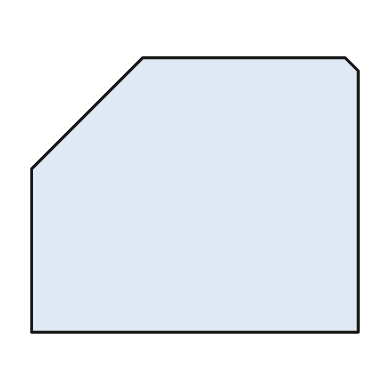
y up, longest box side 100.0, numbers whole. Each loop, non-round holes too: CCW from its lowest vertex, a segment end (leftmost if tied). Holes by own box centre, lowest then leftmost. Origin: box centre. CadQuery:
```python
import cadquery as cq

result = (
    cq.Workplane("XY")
    .moveTo(-50.0, -42.0)
    .lineTo(50.0, -42.0)
    .lineTo(50.0, 38.0)
    .lineTo(46.0, 42.0)
    .lineTo(-16.0, 42.0)
    .lineTo(-50.0, 8.0)
    .close()
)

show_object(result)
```